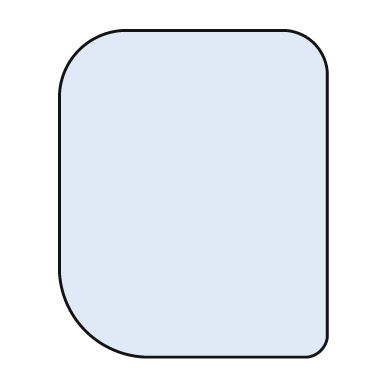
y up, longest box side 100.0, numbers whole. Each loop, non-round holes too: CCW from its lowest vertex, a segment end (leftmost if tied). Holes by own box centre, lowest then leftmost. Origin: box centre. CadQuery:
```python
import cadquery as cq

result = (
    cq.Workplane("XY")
    .moveTo(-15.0, -50.0)
    .lineTo(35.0, -50.0)
    .threePointArc((39.0, -48.0), (41.0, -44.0))
    .lineTo(41.0, 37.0)
    .threePointArc((37.0, 46.0), (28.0, 50.0))
    .lineTo(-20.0, 50.0)
    .threePointArc((-35.0, 44.0), (-41.0, 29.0))
    .lineTo(-41.0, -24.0)
    .threePointArc((-33.0, -42.0), (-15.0, -50.0))
    .close()
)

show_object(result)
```